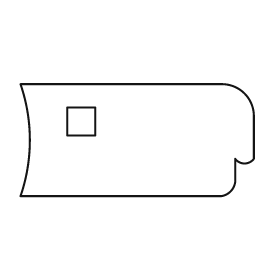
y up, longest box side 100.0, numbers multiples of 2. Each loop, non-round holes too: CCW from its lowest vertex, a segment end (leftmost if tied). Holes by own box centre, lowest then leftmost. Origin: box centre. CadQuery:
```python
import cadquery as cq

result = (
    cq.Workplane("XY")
    .moveTo(-50.0, -24.0)
    .lineTo(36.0, -24.0)
    .threePointArc((40.0, -22.0), (42.0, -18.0))
    .lineTo(42.0, -8.0)
    .threePointArc((46.0, -10.0), (50.0, -8.0))
    .lineTo(50.0, 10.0)
    .threePointArc((46.0, 20.0), (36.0, 24.0))
    .lineTo(-50.0, 24.0)
    .threePointArc((-46.0, 0.0), (-50.0, -24.0))
    .close()
    .moveTo(-30.0, 2.0)
    .lineTo(-18.0, 2.0)
    .lineTo(-18.0, 14.0)
    .lineTo(-30.0, 14.0)
    .close()
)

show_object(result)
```